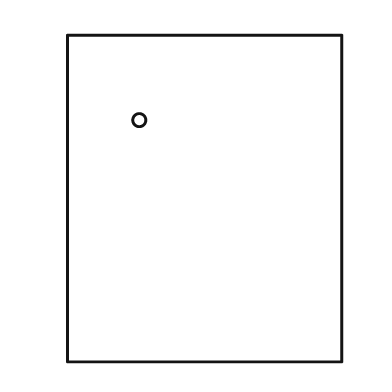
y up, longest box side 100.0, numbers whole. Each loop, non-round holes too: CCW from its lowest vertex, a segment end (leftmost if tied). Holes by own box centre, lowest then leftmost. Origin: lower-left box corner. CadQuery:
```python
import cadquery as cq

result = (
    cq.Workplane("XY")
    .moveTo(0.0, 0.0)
    .lineTo(84.0, 0.0)
    .lineTo(84.0, 100.0)
    .lineTo(0.0, 100.0)
    .close()
    .moveTo(22.0, 74.0)
    .circle(2.0)
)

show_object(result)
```